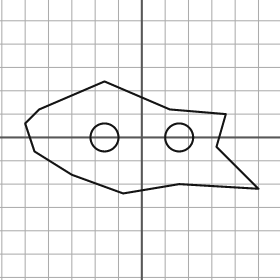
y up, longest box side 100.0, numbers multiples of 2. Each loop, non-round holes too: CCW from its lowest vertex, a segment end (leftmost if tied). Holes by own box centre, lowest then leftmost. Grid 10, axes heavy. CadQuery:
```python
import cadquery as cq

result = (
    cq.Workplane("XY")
    .moveTo(-8.0, -24.0)
    .lineTo(16.0, -20.0)
    .lineTo(50.0, -22.0)
    .lineTo(32.0, -4.0)
    .lineTo(36.0, 10.0)
    .lineTo(12.0, 12.0)
    .lineTo(-16.0, 24.0)
    .lineTo(-44.0, 12.0)
    .lineTo(-50.0, 6.0)
    .lineTo(-46.0, -6.0)
    .lineTo(-30.0, -16.0)
    .close()
    .moveTo(-16.0, 0.0)
    .circle(6.0)
    .moveTo(16.0, 0.0)
    .circle(6.0)
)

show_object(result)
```